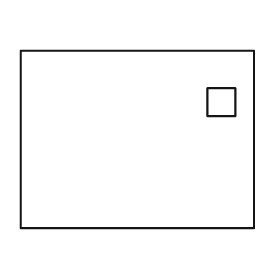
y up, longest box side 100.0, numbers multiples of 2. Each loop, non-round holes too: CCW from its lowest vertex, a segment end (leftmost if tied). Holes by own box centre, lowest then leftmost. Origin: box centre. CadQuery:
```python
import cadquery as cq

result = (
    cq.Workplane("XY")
    .moveTo(-50.0, -38.0)
    .lineTo(50.0, -38.0)
    .lineTo(50.0, 38.0)
    .lineTo(-50.0, 38.0)
    .close()
    .moveTo(30.0, 10.0)
    .lineTo(42.0, 10.0)
    .lineTo(42.0, 22.0)
    .lineTo(30.0, 22.0)
    .close()
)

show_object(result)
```